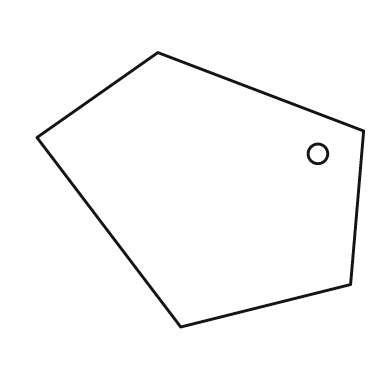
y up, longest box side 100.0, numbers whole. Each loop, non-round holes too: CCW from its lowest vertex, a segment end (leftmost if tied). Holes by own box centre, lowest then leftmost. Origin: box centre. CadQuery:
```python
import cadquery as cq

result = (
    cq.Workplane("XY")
    .moveTo(-6.0, -42.0)
    .lineTo(46.0, -29.0)
    .lineTo(50.0, 18.0)
    .lineTo(-13.0, 42.0)
    .lineTo(-50.0, 16.0)
    .close()
    .moveTo(36.0, 11.0)
    .circle(3.0)
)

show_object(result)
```